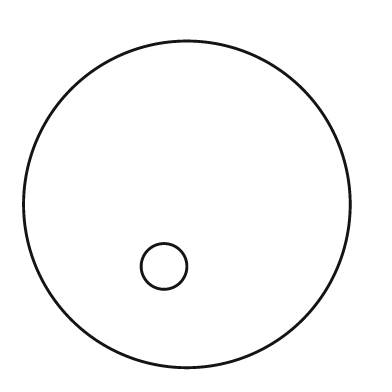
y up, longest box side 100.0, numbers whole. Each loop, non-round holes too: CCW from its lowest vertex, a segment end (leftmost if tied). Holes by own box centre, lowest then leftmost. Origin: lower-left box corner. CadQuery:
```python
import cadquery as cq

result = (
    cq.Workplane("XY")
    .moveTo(50.0, 50.0)
    .circle(50.0)
    .moveTo(43.0, 31.0)
    .circle(7.0)
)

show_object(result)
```